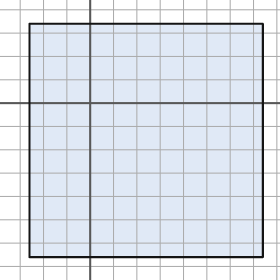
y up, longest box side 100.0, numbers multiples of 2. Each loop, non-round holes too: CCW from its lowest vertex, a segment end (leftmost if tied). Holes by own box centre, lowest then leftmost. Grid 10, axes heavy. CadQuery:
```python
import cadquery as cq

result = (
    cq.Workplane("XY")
    .moveTo(-26.0, -66.0)
    .lineTo(74.0, -66.0)
    .lineTo(74.0, 34.0)
    .lineTo(-26.0, 34.0)
    .close()
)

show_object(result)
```